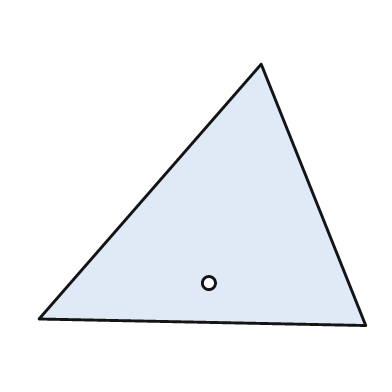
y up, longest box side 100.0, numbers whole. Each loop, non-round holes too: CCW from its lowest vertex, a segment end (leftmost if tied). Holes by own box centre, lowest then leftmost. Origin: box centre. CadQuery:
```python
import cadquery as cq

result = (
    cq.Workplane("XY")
    .moveTo(50.0, -40.0)
    .lineTo(18.0, 40.0)
    .lineTo(-50.0, -38.0)
    .close()
    .moveTo(2.0, -27.0)
    .circle(2.0)
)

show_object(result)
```